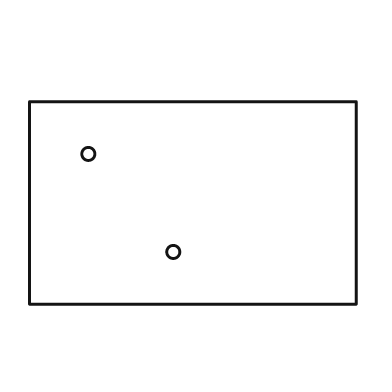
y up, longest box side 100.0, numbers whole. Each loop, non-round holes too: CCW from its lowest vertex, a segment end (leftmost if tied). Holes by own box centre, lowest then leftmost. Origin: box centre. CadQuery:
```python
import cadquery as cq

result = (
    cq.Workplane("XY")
    .moveTo(-50.0, -31.0)
    .lineTo(50.0, -31.0)
    .lineTo(50.0, 31.0)
    .lineTo(-50.0, 31.0)
    .close()
    .moveTo(-6.0, -15.0)
    .circle(2.0)
    .moveTo(-32.0, 15.0)
    .circle(2.0)
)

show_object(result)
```